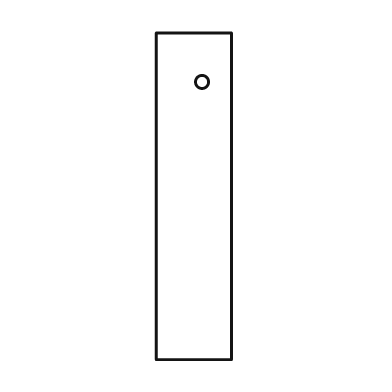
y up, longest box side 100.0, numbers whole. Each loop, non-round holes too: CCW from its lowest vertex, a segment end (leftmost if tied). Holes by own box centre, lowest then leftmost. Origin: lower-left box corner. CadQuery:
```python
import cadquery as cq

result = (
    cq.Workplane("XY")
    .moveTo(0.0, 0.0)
    .lineTo(23.0, 0.0)
    .lineTo(23.0, 100.0)
    .lineTo(0.0, 100.0)
    .close()
    .moveTo(14.0, 85.0)
    .circle(2.0)
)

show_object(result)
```